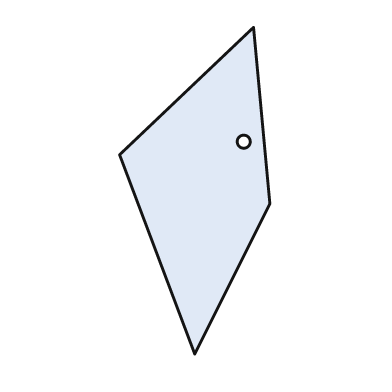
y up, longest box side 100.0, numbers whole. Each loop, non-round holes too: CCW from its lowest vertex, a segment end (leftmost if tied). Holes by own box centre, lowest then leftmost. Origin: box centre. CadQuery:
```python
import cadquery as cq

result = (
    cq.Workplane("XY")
    .moveTo(0.0, -50.0)
    .lineTo(23.0, -4.0)
    .lineTo(18.0, 50.0)
    .lineTo(-23.0, 11.0)
    .close()
    .moveTo(15.0, 15.0)
    .circle(2.0)
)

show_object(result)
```